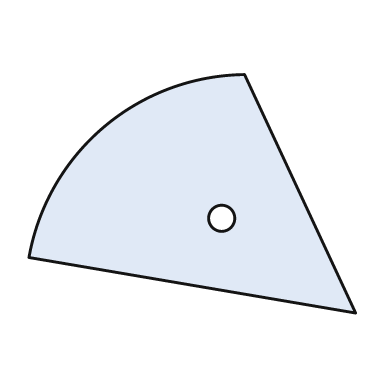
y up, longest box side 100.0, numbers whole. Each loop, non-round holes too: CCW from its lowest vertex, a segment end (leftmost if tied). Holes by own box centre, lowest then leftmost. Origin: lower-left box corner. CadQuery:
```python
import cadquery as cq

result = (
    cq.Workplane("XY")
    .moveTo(100.0, 0.0)
    .lineTo(66.0, 73.0)
    .threePointArc((23.0, 57.0), (0.0, 17.0))
    .close()
    .moveTo(59.0, 29.0)
    .circle(4.0)
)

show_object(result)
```